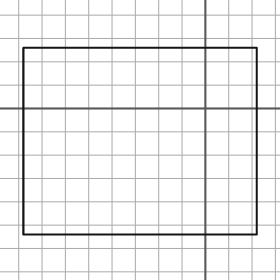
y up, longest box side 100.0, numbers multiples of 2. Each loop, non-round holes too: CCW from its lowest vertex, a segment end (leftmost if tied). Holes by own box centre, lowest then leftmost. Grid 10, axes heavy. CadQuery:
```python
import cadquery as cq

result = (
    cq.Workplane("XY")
    .moveTo(-78.0, -54.0)
    .lineTo(22.0, -54.0)
    .lineTo(22.0, 26.0)
    .lineTo(-78.0, 26.0)
    .close()
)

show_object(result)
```